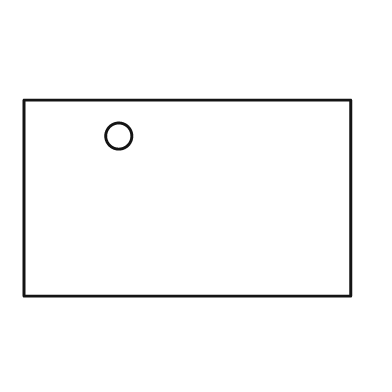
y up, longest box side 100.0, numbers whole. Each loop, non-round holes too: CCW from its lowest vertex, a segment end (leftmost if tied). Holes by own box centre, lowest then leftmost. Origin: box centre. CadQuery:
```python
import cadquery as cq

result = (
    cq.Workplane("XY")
    .moveTo(-50.0, -30.0)
    .lineTo(50.0, -30.0)
    .lineTo(50.0, 30.0)
    .lineTo(-50.0, 30.0)
    .close()
    .moveTo(-21.0, 19.0)
    .circle(4.0)
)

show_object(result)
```